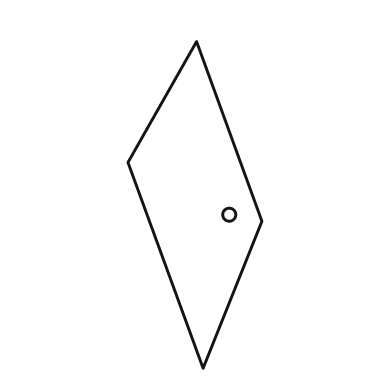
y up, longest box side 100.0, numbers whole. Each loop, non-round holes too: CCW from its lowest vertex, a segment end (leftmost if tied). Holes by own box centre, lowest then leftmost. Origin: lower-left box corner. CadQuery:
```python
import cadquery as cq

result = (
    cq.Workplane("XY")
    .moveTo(23.0, 0.0)
    .lineTo(41.0, 45.0)
    .lineTo(21.0, 100.0)
    .lineTo(0.0, 63.0)
    .close()
    .moveTo(31.0, 47.0)
    .circle(2.0)
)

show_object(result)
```